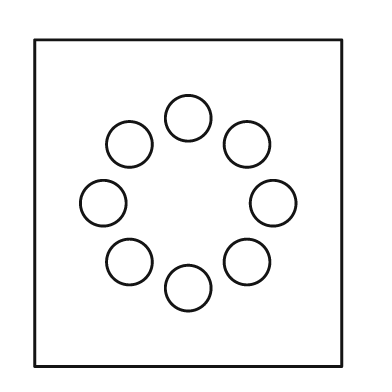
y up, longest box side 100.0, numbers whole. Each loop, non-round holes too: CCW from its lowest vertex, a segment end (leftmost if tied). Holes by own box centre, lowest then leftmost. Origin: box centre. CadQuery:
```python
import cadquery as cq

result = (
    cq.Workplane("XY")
    .moveTo(-47.0, -50.0)
    .lineTo(47.0, -50.0)
    .lineTo(47.0, 50.0)
    .lineTo(-47.0, 50.0)
    .close()
    .moveTo(0.0, -26.0)
    .circle(7.0)
    .moveTo(-18.0, -18.0)
    .circle(7.0)
    .moveTo(18.0, -18.0)
    .circle(7.0)
    .moveTo(-26.0, 0.0)
    .circle(7.0)
    .moveTo(26.0, 0.0)
    .circle(7.0)
    .moveTo(-18.0, 18.0)
    .circle(7.0)
    .moveTo(18.0, 18.0)
    .circle(7.0)
    .moveTo(0.0, 26.0)
    .circle(7.0)
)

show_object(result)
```